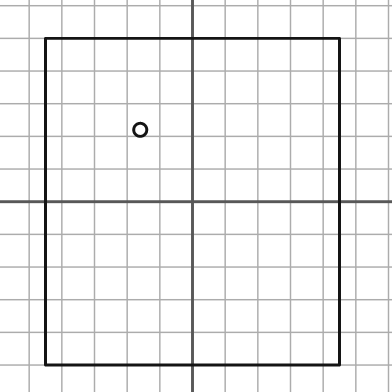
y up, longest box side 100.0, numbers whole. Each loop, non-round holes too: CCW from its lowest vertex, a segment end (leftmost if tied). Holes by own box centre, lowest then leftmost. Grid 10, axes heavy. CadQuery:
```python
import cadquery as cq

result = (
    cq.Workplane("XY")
    .moveTo(-45.0, -50.0)
    .lineTo(45.0, -50.0)
    .lineTo(45.0, 50.0)
    .lineTo(-45.0, 50.0)
    .close()
    .moveTo(-16.0, 22.0)
    .circle(2.0)
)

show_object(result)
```